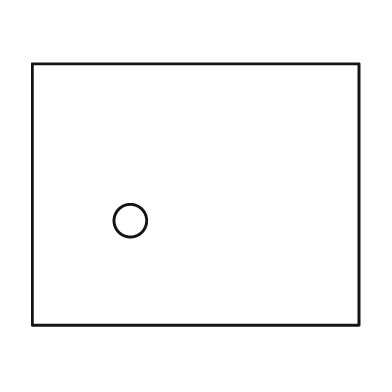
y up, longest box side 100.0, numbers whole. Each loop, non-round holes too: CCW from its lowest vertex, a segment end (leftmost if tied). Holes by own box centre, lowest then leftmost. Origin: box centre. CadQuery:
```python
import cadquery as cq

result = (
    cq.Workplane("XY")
    .moveTo(-50.0, -40.0)
    .lineTo(50.0, -40.0)
    .lineTo(50.0, 40.0)
    .lineTo(-50.0, 40.0)
    .close()
    .moveTo(-20.0, -8.0)
    .circle(5.0)
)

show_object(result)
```